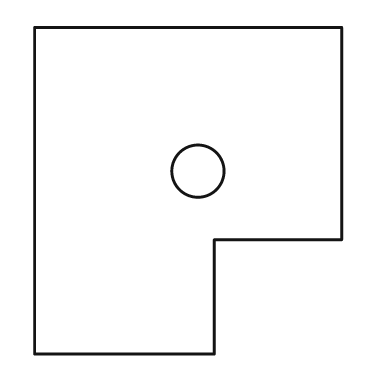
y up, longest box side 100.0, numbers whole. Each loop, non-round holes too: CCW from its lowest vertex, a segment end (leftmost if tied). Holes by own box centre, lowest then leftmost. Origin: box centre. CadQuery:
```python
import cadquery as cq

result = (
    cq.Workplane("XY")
    .moveTo(-47.0, -50.0)
    .lineTo(8.0, -50.0)
    .lineTo(8.0, -15.0)
    .lineTo(47.0, -15.0)
    .lineTo(47.0, 50.0)
    .lineTo(-47.0, 50.0)
    .close()
    .moveTo(3.0, 6.0)
    .circle(8.0)
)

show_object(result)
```